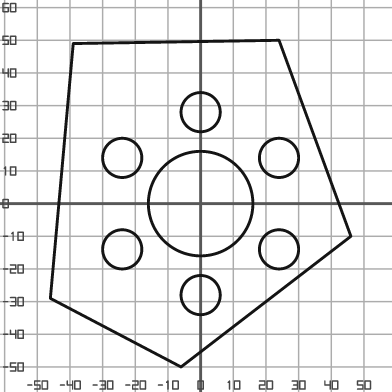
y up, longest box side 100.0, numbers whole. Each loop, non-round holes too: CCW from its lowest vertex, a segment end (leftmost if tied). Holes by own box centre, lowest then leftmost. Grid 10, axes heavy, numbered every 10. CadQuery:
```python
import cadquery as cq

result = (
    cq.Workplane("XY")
    .moveTo(-6.0, -50.0)
    .lineTo(46.0, -10.0)
    .lineTo(24.0, 50.0)
    .lineTo(-39.0, 49.0)
    .lineTo(-46.0, -29.0)
    .close()
    .moveTo(0.0, -28.0)
    .circle(6.0)
    .moveTo(-24.0, -14.0)
    .circle(6.0)
    .moveTo(24.0, -14.0)
    .circle(6.0)
    .moveTo(0.0, 0.0)
    .circle(16.0)
    .moveTo(-24.0, 14.0)
    .circle(6.0)
    .moveTo(24.0, 14.0)
    .circle(6.0)
    .moveTo(0.0, 28.0)
    .circle(6.0)
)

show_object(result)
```